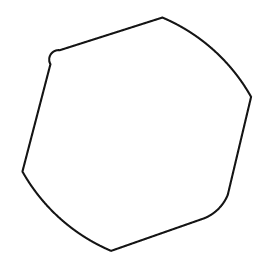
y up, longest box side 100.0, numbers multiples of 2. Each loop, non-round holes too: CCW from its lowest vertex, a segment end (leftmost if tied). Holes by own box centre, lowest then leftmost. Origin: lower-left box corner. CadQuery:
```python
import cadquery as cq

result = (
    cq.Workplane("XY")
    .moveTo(38.0, 0.0)
    .lineTo(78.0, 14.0)
    .threePointArc((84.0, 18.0), (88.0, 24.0))
    .lineTo(98.0, 66.0)
    .threePointArc((82.0, 86.0), (60.0, 100.0))
    .lineTo(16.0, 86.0)
    .threePointArc((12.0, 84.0), (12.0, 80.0))
    .lineTo(0.0, 34.0)
    .threePointArc((16.0, 14.0), (38.0, 0.0))
    .close()
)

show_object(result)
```